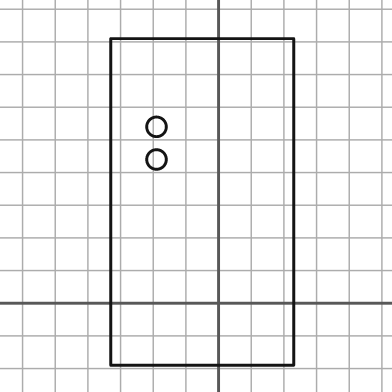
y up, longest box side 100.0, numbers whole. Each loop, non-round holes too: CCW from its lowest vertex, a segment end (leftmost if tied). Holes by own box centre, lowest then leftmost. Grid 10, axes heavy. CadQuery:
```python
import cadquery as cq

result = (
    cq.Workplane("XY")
    .moveTo(-33.0, -19.0)
    .lineTo(23.0, -19.0)
    .lineTo(23.0, 81.0)
    .lineTo(-33.0, 81.0)
    .close()
    .moveTo(-19.0, 44.0)
    .circle(3.0)
    .moveTo(-19.0, 54.0)
    .circle(3.0)
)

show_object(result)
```